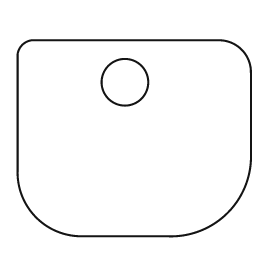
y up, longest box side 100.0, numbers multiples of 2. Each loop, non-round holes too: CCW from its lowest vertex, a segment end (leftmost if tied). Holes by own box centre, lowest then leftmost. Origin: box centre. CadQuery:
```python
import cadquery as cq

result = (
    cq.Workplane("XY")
    .moveTo(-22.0, -42.0)
    .lineTo(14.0, -42.0)
    .threePointArc((40.0, -32.0), (50.0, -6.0))
    .lineTo(50.0, 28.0)
    .threePointArc((46.0, 38.0), (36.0, 42.0))
    .lineTo(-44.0, 42.0)
    .threePointArc((-48.0, 40.0), (-50.0, 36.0))
    .lineTo(-50.0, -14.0)
    .threePointArc((-42.0, -34.0), (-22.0, -42.0))
    .close()
    .moveTo(-4.0, 24.0)
    .circle(10.0)
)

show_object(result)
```